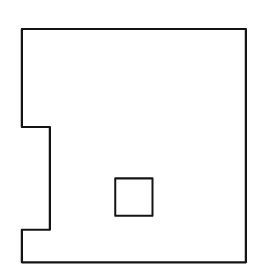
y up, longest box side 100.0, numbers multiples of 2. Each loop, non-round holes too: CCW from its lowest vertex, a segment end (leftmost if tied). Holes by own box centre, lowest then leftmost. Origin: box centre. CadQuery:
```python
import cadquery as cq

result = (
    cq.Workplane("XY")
    .moveTo(-48.0, -50.0)
    .lineTo(48.0, -50.0)
    .lineTo(48.0, 50.0)
    .lineTo(-48.0, 50.0)
    .lineTo(-48.0, 8.0)
    .lineTo(-36.0, 8.0)
    .lineTo(-36.0, -36.0)
    .lineTo(-48.0, -36.0)
    .close()
    .moveTo(-8.0, -30.0)
    .lineTo(8.0, -30.0)
    .lineTo(8.0, -14.0)
    .lineTo(-8.0, -14.0)
    .close()
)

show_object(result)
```